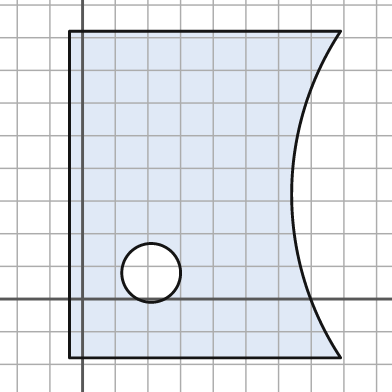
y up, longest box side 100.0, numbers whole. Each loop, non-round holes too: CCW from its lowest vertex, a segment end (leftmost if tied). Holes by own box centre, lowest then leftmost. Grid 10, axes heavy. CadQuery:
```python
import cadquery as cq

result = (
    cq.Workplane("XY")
    .moveTo(-4.0, -18.0)
    .lineTo(79.0, -18.0)
    .threePointArc((64.0, 32.0), (79.0, 82.0))
    .lineTo(-4.0, 82.0)
    .close()
    .moveTo(21.0, 8.0)
    .circle(9.0)
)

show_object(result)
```